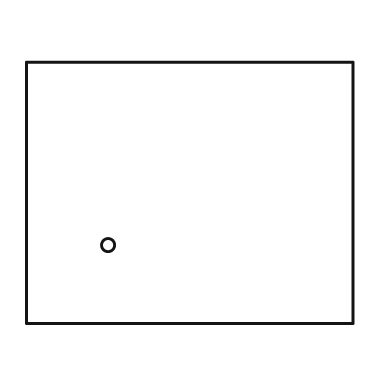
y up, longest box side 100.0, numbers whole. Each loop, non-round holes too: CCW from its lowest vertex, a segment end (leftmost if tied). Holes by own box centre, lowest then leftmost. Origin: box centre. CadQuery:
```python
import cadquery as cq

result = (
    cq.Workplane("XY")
    .moveTo(-50.0, -40.0)
    .lineTo(50.0, -40.0)
    .lineTo(50.0, 40.0)
    .lineTo(-50.0, 40.0)
    .close()
    .moveTo(-25.0, -16.0)
    .circle(2.0)
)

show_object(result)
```